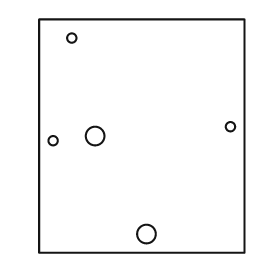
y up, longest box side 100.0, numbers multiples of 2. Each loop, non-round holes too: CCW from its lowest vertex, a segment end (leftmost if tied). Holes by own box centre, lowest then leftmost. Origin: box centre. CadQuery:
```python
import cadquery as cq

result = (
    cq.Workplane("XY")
    .moveTo(-44.0, -50.0)
    .lineTo(44.0, -50.0)
    .lineTo(44.0, 50.0)
    .lineTo(-44.0, 50.0)
    .close()
    .moveTo(2.0, -42.0)
    .circle(4.0)
    .moveTo(-38.0, -2.0)
    .circle(2.0)
    .moveTo(-20.0, 0.0)
    .circle(4.0)
    .moveTo(38.0, 4.0)
    .circle(2.0)
    .moveTo(-30.0, 42.0)
    .circle(2.0)
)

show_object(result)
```